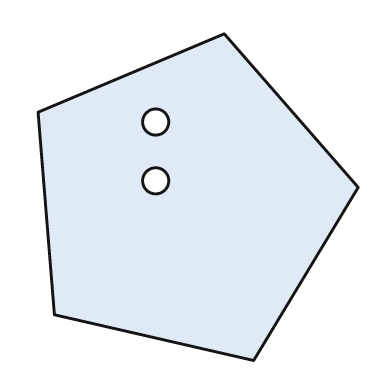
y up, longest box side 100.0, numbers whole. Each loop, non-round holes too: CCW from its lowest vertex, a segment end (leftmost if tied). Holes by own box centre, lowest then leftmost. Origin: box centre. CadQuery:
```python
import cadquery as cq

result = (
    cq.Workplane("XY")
    .moveTo(17.0, -50.0)
    .lineTo(49.0, 3.0)
    .lineTo(8.0, 50.0)
    .lineTo(-49.0, 26.0)
    .lineTo(-44.0, -36.0)
    .close()
    .moveTo(-13.0, 5.0)
    .circle(4.0)
    .moveTo(-13.0, 23.0)
    .circle(4.0)
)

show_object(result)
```